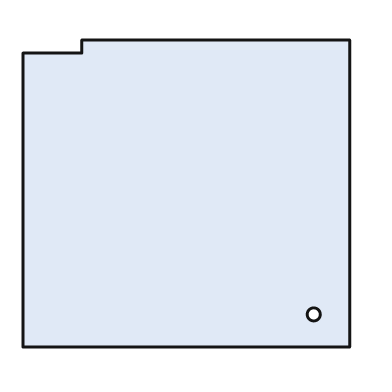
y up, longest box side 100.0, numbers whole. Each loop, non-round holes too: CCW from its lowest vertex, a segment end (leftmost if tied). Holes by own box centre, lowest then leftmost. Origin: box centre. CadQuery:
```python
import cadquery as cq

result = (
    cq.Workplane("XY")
    .moveTo(-50.0, -47.0)
    .lineTo(50.0, -47.0)
    .lineTo(50.0, 47.0)
    .lineTo(-32.0, 47.0)
    .lineTo(-32.0, 43.0)
    .lineTo(-50.0, 43.0)
    .close()
    .moveTo(39.0, -37.0)
    .circle(2.0)
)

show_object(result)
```